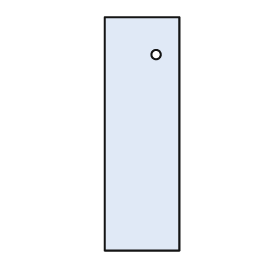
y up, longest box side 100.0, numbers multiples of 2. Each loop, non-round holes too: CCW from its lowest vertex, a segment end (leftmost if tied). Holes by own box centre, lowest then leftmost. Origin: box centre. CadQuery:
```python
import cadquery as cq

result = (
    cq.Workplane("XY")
    .moveTo(-16.0, -50.0)
    .lineTo(16.0, -50.0)
    .lineTo(16.0, 50.0)
    .lineTo(-16.0, 50.0)
    .close()
    .moveTo(6.0, 34.0)
    .circle(2.0)
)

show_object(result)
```